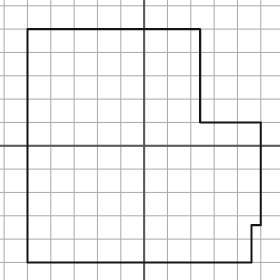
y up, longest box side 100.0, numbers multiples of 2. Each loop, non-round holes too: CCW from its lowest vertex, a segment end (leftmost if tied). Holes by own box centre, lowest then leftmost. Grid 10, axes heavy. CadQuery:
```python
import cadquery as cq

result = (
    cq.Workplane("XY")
    .moveTo(-50.0, -50.0)
    .lineTo(46.0, -50.0)
    .lineTo(46.0, -34.0)
    .lineTo(50.0, -34.0)
    .lineTo(50.0, 10.0)
    .lineTo(24.0, 10.0)
    .lineTo(24.0, 50.0)
    .lineTo(-50.0, 50.0)
    .close()
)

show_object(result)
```